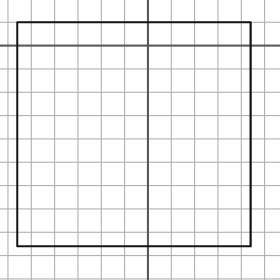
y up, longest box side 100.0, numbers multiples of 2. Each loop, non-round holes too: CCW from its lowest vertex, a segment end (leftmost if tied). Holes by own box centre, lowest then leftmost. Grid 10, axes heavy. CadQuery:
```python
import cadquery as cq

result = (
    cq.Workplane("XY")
    .moveTo(-56.0, -86.0)
    .lineTo(44.0, -86.0)
    .lineTo(44.0, 10.0)
    .lineTo(-56.0, 10.0)
    .close()
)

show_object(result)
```